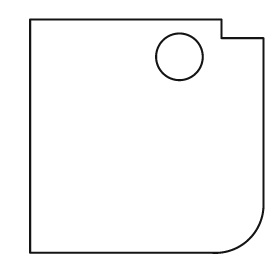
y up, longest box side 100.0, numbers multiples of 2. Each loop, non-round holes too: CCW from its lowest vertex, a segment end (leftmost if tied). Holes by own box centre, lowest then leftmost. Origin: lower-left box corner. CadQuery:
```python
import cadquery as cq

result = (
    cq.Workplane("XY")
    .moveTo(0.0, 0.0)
    .lineTo(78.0, 0.0)
    .threePointArc((94.0, 6.0), (100.0, 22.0))
    .lineTo(100.0, 92.0)
    .lineTo(82.0, 92.0)
    .lineTo(82.0, 100.0)
    .lineTo(0.0, 100.0)
    .close()
    .moveTo(64.0, 84.0)
    .circle(10.0)
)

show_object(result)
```